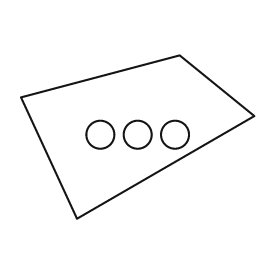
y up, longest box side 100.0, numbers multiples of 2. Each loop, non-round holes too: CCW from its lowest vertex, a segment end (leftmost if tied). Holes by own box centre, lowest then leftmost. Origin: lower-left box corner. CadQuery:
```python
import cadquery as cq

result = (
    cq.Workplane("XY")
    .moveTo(24.0, 0.0)
    .lineTo(100.0, 44.0)
    .lineTo(68.0, 70.0)
    .lineTo(0.0, 52.0)
    .close()
    .moveTo(34.0, 36.0)
    .circle(6.0)
    .moveTo(50.0, 36.0)
    .circle(6.0)
    .moveTo(66.0, 36.0)
    .circle(6.0)
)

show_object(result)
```